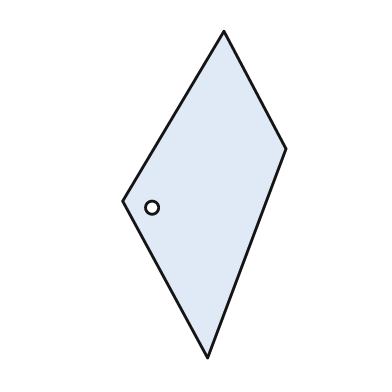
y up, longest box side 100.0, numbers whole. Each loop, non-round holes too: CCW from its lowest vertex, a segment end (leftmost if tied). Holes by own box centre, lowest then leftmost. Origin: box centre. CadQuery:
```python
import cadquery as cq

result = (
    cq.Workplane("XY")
    .moveTo(1.0, -50.0)
    .lineTo(25.0, 14.0)
    .lineTo(6.0, 50.0)
    .lineTo(-25.0, -2.0)
    .close()
    .moveTo(-16.0, -4.0)
    .circle(2.0)
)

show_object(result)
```